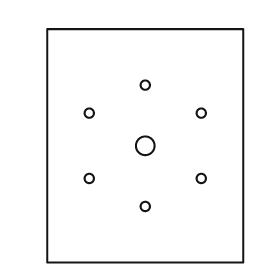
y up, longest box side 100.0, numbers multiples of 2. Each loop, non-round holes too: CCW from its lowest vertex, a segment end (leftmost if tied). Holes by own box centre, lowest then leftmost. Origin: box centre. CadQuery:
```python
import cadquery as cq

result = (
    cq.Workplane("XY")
    .moveTo(-42.0, -50.0)
    .lineTo(42.0, -50.0)
    .lineTo(42.0, 50.0)
    .lineTo(-42.0, 50.0)
    .close()
    .moveTo(0.0, -26.0)
    .circle(2.0)
    .moveTo(-24.0, -14.0)
    .circle(2.0)
    .moveTo(24.0, -14.0)
    .circle(2.0)
    .moveTo(0.0, 0.0)
    .circle(4.0)
    .moveTo(-24.0, 14.0)
    .circle(2.0)
    .moveTo(24.0, 14.0)
    .circle(2.0)
    .moveTo(0.0, 26.0)
    .circle(2.0)
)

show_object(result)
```